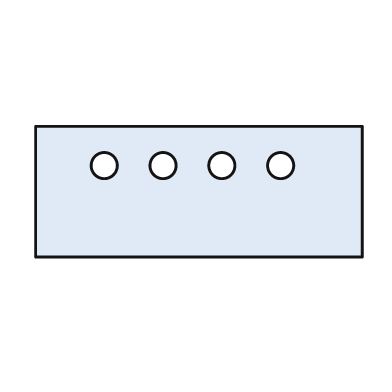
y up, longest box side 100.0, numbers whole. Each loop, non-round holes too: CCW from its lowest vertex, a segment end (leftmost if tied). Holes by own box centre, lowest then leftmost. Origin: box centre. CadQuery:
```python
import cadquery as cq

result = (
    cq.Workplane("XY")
    .moveTo(-50.0, -20.0)
    .lineTo(50.0, -20.0)
    .lineTo(50.0, 20.0)
    .lineTo(-50.0, 20.0)
    .close()
    .moveTo(-29.0, 8.0)
    .circle(4.0)
    .moveTo(-11.0, 8.0)
    .circle(4.0)
    .moveTo(7.0, 8.0)
    .circle(4.0)
    .moveTo(25.0, 8.0)
    .circle(4.0)
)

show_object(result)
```